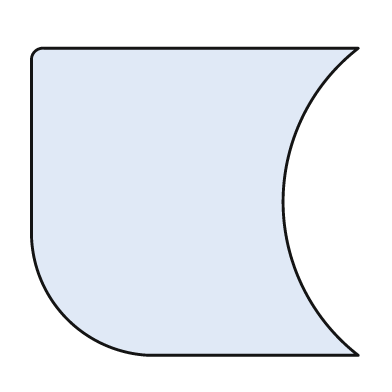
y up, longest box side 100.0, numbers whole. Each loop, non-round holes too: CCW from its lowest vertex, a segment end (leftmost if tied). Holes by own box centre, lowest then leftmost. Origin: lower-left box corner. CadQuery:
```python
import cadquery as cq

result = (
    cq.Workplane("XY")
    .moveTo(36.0, 0.0)
    .lineTo(100.0, 0.0)
    .threePointArc((77.0, 47.0), (100.0, 94.0))
    .lineTo(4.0, 94.0)
    .threePointArc((1.0, 93.0), (0.0, 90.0))
    .lineTo(0.0, 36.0)
    .threePointArc((11.0, 11.0), (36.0, 0.0))
    .close()
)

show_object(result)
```